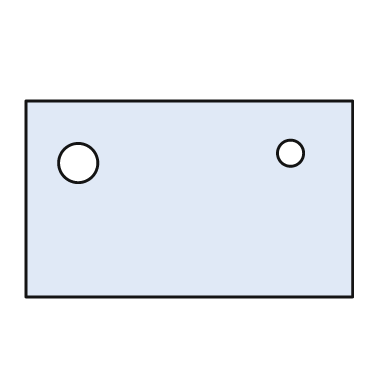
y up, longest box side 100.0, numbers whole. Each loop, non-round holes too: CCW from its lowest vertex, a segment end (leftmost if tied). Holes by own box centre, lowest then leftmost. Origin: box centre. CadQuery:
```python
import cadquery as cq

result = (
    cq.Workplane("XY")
    .moveTo(-50.0, -30.0)
    .lineTo(50.0, -30.0)
    .lineTo(50.0, 30.0)
    .lineTo(-50.0, 30.0)
    .close()
    .moveTo(-34.0, 11.0)
    .circle(6.0)
    .moveTo(31.0, 14.0)
    .circle(4.0)
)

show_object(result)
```